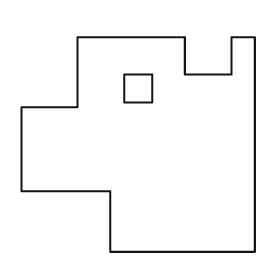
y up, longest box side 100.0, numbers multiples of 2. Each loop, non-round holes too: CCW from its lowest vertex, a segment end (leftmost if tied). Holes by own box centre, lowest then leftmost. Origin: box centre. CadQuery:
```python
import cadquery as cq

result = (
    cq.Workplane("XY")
    .moveTo(-12.0, -46.0)
    .lineTo(50.0, -46.0)
    .lineTo(50.0, 46.0)
    .lineTo(40.0, 46.0)
    .lineTo(40.0, 30.0)
    .lineTo(20.0, 30.0)
    .lineTo(20.0, 46.0)
    .lineTo(-26.0, 46.0)
    .lineTo(-26.0, 16.0)
    .lineTo(-50.0, 16.0)
    .lineTo(-50.0, -20.0)
    .lineTo(-12.0, -20.0)
    .close()
    .moveTo(-6.0, 18.0)
    .lineTo(6.0, 18.0)
    .lineTo(6.0, 30.0)
    .lineTo(-6.0, 30.0)
    .close()
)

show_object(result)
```